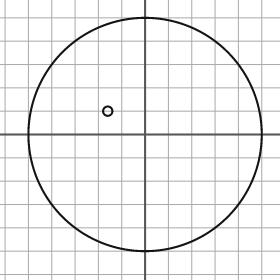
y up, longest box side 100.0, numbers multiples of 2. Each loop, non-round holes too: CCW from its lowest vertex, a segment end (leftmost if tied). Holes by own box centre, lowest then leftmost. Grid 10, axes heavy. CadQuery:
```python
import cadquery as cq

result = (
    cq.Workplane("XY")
    .moveTo(0.0, 0.0)
    .circle(50.0)
    .moveTo(-16.0, 10.0)
    .circle(2.0)
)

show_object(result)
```